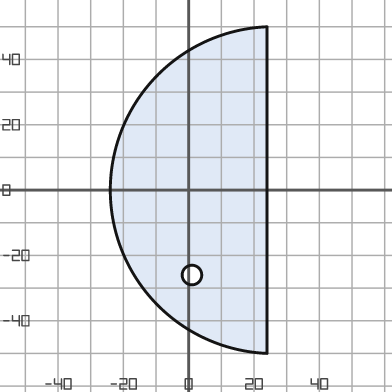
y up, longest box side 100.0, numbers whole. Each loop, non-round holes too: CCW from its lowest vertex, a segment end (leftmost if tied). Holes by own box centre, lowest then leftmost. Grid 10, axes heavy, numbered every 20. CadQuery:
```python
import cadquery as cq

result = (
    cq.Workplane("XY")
    .moveTo(24.0, -50.0)
    .lineTo(24.0, 50.0)
    .threePointArc((-24.0, 0.0), (24.0, -50.0))
    .close()
    .moveTo(1.0, -26.0)
    .circle(3.0)
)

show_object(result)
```